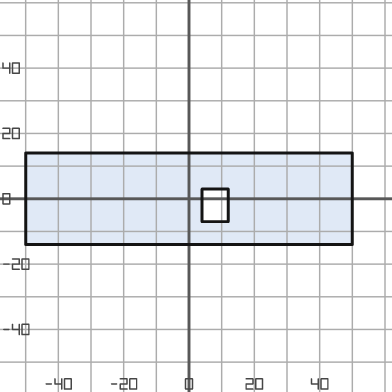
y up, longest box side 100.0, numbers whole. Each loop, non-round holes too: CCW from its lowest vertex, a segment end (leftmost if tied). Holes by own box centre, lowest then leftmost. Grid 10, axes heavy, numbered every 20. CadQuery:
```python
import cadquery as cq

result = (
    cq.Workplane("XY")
    .moveTo(-50.0, -14.0)
    .lineTo(50.0, -14.0)
    .lineTo(50.0, 14.0)
    .lineTo(-50.0, 14.0)
    .close()
    .moveTo(4.0, -7.0)
    .lineTo(12.0, -7.0)
    .lineTo(12.0, 3.0)
    .lineTo(4.0, 3.0)
    .close()
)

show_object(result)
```